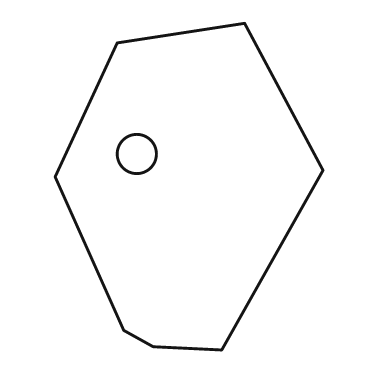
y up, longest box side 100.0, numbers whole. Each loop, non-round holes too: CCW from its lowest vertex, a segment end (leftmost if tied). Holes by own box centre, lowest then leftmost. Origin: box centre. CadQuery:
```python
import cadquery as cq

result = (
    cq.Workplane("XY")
    .moveTo(10.0, -50.0)
    .lineTo(41.0, 5.0)
    .lineTo(17.0, 50.0)
    .lineTo(-22.0, 44.0)
    .lineTo(-41.0, 3.0)
    .lineTo(-20.0, -44.0)
    .lineTo(-11.0, -49.0)
    .close()
    .moveTo(-16.0, 10.0)
    .circle(6.0)
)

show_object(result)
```